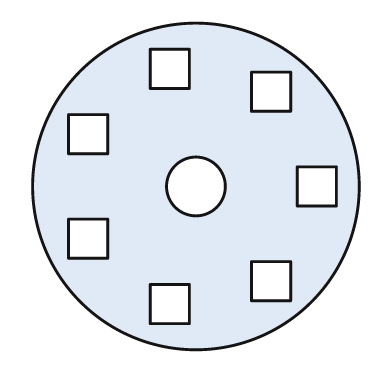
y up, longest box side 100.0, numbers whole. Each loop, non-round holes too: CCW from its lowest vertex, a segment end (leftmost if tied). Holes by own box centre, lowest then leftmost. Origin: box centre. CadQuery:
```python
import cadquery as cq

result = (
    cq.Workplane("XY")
    .moveTo(0.0, 0.0)
    .circle(50.0)
    .moveTo(-14.0, -42.0)
    .lineTo(-2.0, -42.0)
    .lineTo(-2.0, -30.0)
    .lineTo(-14.0, -30.0)
    .close()
    .moveTo(17.0, -35.0)
    .lineTo(29.0, -35.0)
    .lineTo(29.0, -23.0)
    .lineTo(17.0, -23.0)
    .close()
    .moveTo(-39.0, -22.0)
    .lineTo(-27.0, -22.0)
    .lineTo(-27.0, -10.0)
    .lineTo(-39.0, -10.0)
    .close()
    .moveTo(0.0, 0.0)
    .circle(9.0)
    .moveTo(31.0, -6.0)
    .lineTo(43.0, -6.0)
    .lineTo(43.0, 6.0)
    .lineTo(31.0, 6.0)
    .close()
    .moveTo(-39.0, 10.0)
    .lineTo(-27.0, 10.0)
    .lineTo(-27.0, 22.0)
    .lineTo(-39.0, 22.0)
    .close()
    .moveTo(17.0, 23.0)
    .lineTo(29.0, 23.0)
    .lineTo(29.0, 35.0)
    .lineTo(17.0, 35.0)
    .close()
    .moveTo(-14.0, 30.0)
    .lineTo(-2.0, 30.0)
    .lineTo(-2.0, 42.0)
    .lineTo(-14.0, 42.0)
    .close()
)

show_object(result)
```